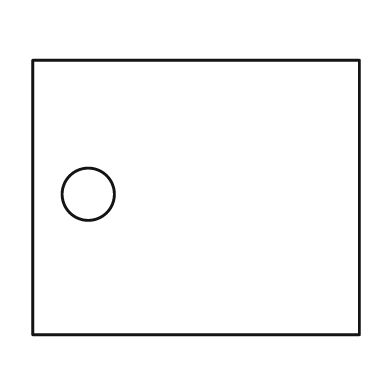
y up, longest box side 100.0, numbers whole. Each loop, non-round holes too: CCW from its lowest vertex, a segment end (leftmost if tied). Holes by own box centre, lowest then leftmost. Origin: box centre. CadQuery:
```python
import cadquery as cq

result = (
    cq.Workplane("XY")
    .moveTo(-50.0, -42.0)
    .lineTo(50.0, -42.0)
    .lineTo(50.0, 42.0)
    .lineTo(-50.0, 42.0)
    .close()
    .moveTo(-33.0, 1.0)
    .circle(8.0)
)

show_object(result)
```